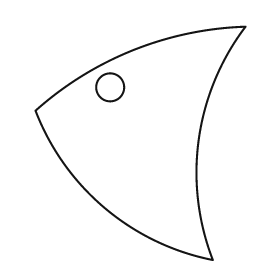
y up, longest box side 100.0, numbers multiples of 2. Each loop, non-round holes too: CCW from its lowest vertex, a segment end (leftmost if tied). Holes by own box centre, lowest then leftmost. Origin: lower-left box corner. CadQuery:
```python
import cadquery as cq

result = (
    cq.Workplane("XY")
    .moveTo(76.0, 0.0)
    .threePointArc((70.0, 52.0), (90.0, 100.0))
    .threePointArc((42.0, 90.0), (0.0, 64.0))
    .threePointArc((30.0, 22.0), (76.0, 0.0))
    .close()
    .moveTo(32.0, 74.0)
    .circle(6.0)
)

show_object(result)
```